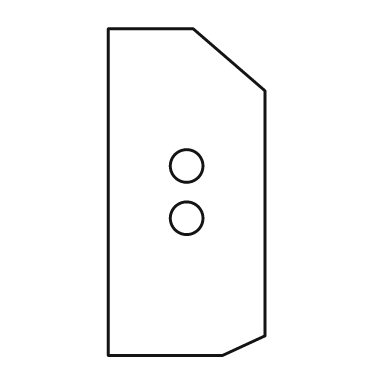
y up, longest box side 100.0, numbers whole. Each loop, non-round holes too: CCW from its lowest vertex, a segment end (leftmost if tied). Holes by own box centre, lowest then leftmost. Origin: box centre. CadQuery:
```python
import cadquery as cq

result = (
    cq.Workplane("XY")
    .moveTo(-24.0, -50.0)
    .lineTo(11.0, -50.0)
    .lineTo(24.0, -44.0)
    .lineTo(24.0, 31.0)
    .lineTo(2.0, 50.0)
    .lineTo(-24.0, 50.0)
    .close()
    .moveTo(0.0, -8.0)
    .circle(5.0)
    .moveTo(0.0, 8.0)
    .circle(5.0)
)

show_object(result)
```